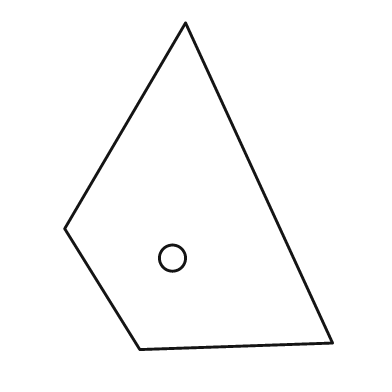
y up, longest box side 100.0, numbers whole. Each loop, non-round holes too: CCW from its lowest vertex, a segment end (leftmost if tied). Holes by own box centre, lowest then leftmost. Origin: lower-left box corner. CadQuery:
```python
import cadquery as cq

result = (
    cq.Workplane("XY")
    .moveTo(23.0, 0.0)
    .lineTo(82.0, 2.0)
    .lineTo(37.0, 100.0)
    .lineTo(0.0, 37.0)
    .close()
    .moveTo(33.0, 28.0)
    .circle(4.0)
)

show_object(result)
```